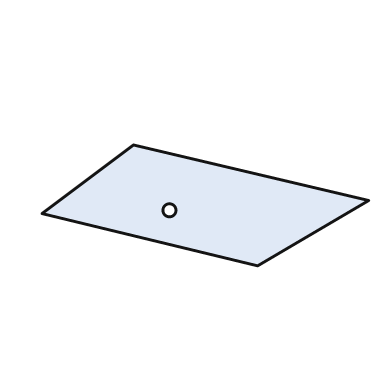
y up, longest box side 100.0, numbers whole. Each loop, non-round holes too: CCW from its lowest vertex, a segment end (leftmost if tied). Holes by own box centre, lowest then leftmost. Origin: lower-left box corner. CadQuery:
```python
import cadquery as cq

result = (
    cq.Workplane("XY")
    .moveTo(66.0, 0.0)
    .lineTo(100.0, 20.0)
    .lineTo(28.0, 37.0)
    .lineTo(0.0, 16.0)
    .close()
    .moveTo(39.0, 17.0)
    .circle(2.0)
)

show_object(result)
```